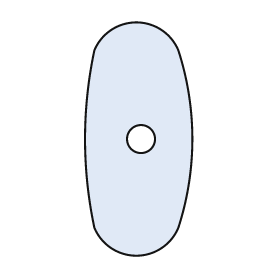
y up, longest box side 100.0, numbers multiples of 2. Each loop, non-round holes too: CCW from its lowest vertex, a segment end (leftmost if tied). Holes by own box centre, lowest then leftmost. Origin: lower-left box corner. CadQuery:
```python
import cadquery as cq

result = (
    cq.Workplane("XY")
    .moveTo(4.0, 12.0)
    .threePointArc((22.0, 0.0), (40.0, 12.0))
    .threePointArc((46.0, 50.0), (40.0, 88.0))
    .threePointArc((22.0, 100.0), (4.0, 88.0))
    .threePointArc((0.0, 50.0), (4.0, 12.0))
    .close()
    .moveTo(24.0, 50.0)
    .circle(6.0)
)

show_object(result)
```